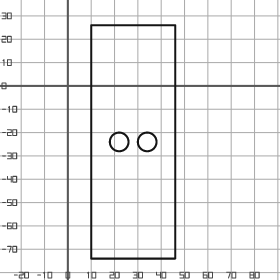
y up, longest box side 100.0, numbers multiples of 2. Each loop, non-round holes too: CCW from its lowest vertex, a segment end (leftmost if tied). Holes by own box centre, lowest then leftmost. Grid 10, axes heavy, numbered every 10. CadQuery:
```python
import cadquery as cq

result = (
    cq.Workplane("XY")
    .moveTo(10.0, -74.0)
    .lineTo(46.0, -74.0)
    .lineTo(46.0, 26.0)
    .lineTo(10.0, 26.0)
    .close()
    .moveTo(22.0, -24.0)
    .circle(4.0)
    .moveTo(34.0, -24.0)
    .circle(4.0)
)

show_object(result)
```